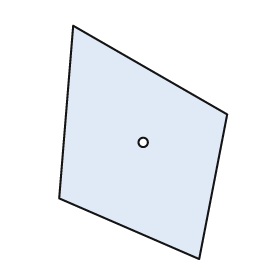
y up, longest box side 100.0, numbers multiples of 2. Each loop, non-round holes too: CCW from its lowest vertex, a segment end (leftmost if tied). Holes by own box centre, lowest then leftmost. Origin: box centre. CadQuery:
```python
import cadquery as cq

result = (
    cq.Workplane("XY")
    .moveTo(24.0, -50.0)
    .lineTo(36.0, 12.0)
    .lineTo(-30.0, 50.0)
    .lineTo(-36.0, -24.0)
    .close()
    .moveTo(0.0, 0.0)
    .circle(2.0)
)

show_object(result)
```